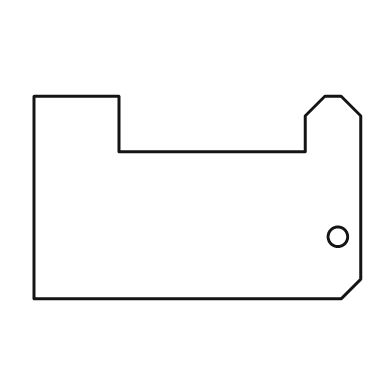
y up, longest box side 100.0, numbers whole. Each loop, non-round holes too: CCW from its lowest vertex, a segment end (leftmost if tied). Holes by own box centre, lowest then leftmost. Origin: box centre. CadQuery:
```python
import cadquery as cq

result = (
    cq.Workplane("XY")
    .moveTo(-50.0, -31.0)
    .lineTo(44.0, -31.0)
    .lineTo(50.0, -25.0)
    .lineTo(50.0, 25.0)
    .lineTo(44.0, 31.0)
    .lineTo(39.0, 31.0)
    .lineTo(33.0, 25.0)
    .lineTo(33.0, 14.0)
    .lineTo(-24.0, 14.0)
    .lineTo(-24.0, 31.0)
    .lineTo(-50.0, 31.0)
    .close()
    .moveTo(43.0, -12.0)
    .circle(3.0)
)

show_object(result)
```